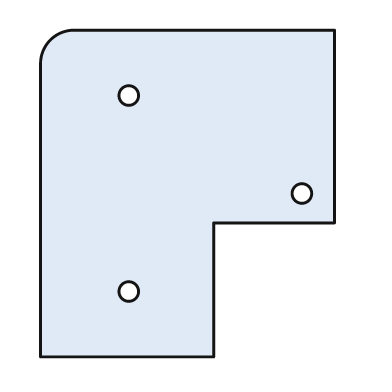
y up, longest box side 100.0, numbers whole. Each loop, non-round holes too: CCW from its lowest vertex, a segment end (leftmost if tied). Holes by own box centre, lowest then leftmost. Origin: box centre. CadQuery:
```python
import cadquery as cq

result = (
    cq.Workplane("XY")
    .moveTo(-45.0, -50.0)
    .lineTo(8.0, -50.0)
    .lineTo(8.0, -9.0)
    .lineTo(45.0, -9.0)
    .lineTo(45.0, 50.0)
    .lineTo(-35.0, 50.0)
    .threePointArc((-42.0, 47.0), (-45.0, 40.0))
    .close()
    .moveTo(-18.0, -30.0)
    .circle(3.0)
    .moveTo(35.0, 0.0)
    .circle(3.0)
    .moveTo(-18.0, 30.0)
    .circle(3.0)
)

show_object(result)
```